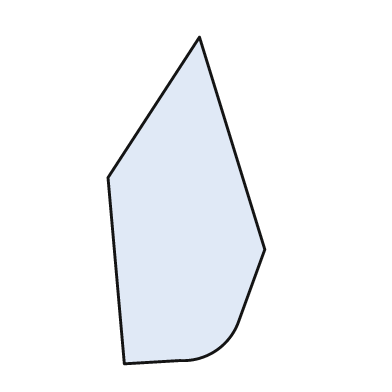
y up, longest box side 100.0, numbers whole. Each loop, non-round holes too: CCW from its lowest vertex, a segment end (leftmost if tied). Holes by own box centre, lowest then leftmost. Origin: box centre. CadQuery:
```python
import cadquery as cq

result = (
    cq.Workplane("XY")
    .moveTo(-19.0, -50.0)
    .lineTo(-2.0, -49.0)
    .threePointArc((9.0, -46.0), (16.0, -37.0))
    .lineTo(24.0, -15.0)
    .lineTo(4.0, 50.0)
    .lineTo(-24.0, 7.0)
    .close()
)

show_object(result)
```